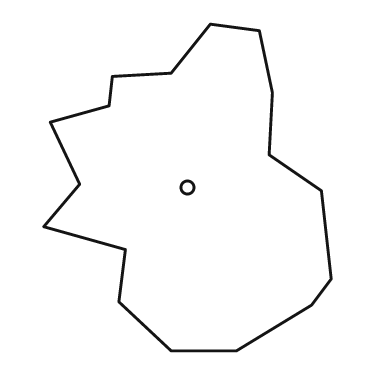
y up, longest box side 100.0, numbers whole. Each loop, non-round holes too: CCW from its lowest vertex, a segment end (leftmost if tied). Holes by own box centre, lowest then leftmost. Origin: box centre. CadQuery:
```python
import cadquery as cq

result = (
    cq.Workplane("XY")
    .moveTo(-5.0, -50.0)
    .lineTo(15.0, -50.0)
    .lineTo(38.0, -36.0)
    .lineTo(44.0, -28.0)
    .lineTo(41.0, -1.0)
    .lineTo(25.0, 10.0)
    .lineTo(26.0, 29.0)
    .lineTo(22.0, 48.0)
    .lineTo(7.0, 50.0)
    .lineTo(-5.0, 35.0)
    .lineTo(-23.0, 34.0)
    .lineTo(-24.0, 25.0)
    .lineTo(-42.0, 20.0)
    .lineTo(-33.0, 1.0)
    .lineTo(-44.0, -12.0)
    .lineTo(-19.0, -19.0)
    .lineTo(-21.0, -35.0)
    .close()
    .moveTo(0.0, 0.0)
    .circle(2.0)
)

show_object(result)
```